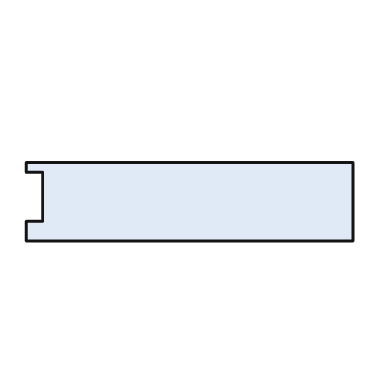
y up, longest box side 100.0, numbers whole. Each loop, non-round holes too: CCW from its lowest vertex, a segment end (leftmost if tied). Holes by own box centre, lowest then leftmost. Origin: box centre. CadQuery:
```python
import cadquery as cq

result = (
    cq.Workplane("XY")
    .moveTo(-50.0, -12.0)
    .lineTo(50.0, -12.0)
    .lineTo(50.0, 12.0)
    .lineTo(-50.0, 12.0)
    .lineTo(-50.0, 9.0)
    .lineTo(-45.0, 9.0)
    .lineTo(-45.0, -6.0)
    .lineTo(-50.0, -6.0)
    .close()
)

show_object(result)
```